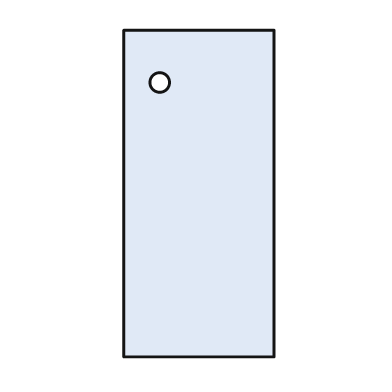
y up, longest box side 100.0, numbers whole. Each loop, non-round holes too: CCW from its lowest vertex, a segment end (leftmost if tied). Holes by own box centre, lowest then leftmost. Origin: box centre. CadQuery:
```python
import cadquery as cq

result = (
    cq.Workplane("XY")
    .moveTo(-23.0, -50.0)
    .lineTo(23.0, -50.0)
    .lineTo(23.0, 50.0)
    .lineTo(-23.0, 50.0)
    .close()
    .moveTo(-12.0, 34.0)
    .circle(3.0)
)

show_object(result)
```